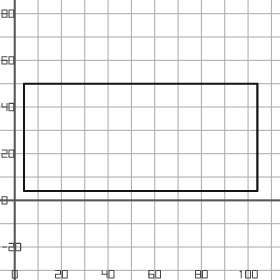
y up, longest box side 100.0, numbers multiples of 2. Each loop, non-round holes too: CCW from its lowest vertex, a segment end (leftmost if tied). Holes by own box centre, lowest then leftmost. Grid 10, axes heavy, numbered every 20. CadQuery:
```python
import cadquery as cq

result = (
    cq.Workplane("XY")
    .moveTo(4.0, 4.0)
    .lineTo(104.0, 4.0)
    .lineTo(104.0, 50.0)
    .lineTo(4.0, 50.0)
    .close()
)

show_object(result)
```